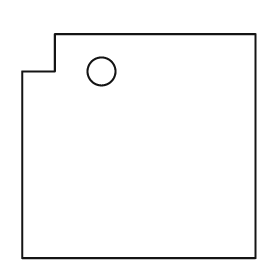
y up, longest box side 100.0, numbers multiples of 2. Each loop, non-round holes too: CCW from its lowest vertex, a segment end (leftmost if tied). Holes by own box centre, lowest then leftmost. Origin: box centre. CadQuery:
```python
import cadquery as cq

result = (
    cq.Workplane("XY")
    .moveTo(-50.0, -48.0)
    .lineTo(50.0, -48.0)
    .lineTo(50.0, 48.0)
    .lineTo(-36.0, 48.0)
    .lineTo(-36.0, 32.0)
    .lineTo(-50.0, 32.0)
    .close()
    .moveTo(-16.0, 32.0)
    .circle(6.0)
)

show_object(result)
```